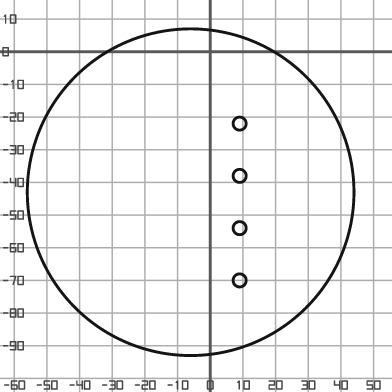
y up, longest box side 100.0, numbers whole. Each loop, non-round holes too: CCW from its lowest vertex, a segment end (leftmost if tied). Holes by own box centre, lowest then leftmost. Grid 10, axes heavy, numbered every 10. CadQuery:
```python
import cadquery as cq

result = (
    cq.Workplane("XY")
    .moveTo(-6.0, -43.0)
    .circle(50.0)
    .moveTo(9.0, -70.0)
    .circle(2.0)
    .moveTo(9.0, -54.0)
    .circle(2.0)
    .moveTo(9.0, -38.0)
    .circle(2.0)
    .moveTo(9.0, -22.0)
    .circle(2.0)
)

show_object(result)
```